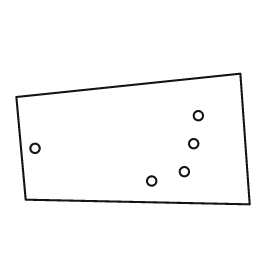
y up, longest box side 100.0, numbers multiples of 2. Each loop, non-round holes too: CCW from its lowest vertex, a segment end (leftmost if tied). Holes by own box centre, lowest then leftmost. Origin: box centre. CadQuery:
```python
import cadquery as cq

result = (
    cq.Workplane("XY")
    .moveTo(50.0, -28.0)
    .lineTo(46.0, 28.0)
    .lineTo(-50.0, 18.0)
    .lineTo(-46.0, -26.0)
    .close()
    .moveTo(8.0, -18.0)
    .circle(2.0)
    .moveTo(22.0, -14.0)
    .circle(2.0)
    .moveTo(-42.0, -4.0)
    .circle(2.0)
    .moveTo(26.0, -2.0)
    .circle(2.0)
    .moveTo(28.0, 10.0)
    .circle(2.0)
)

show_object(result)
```